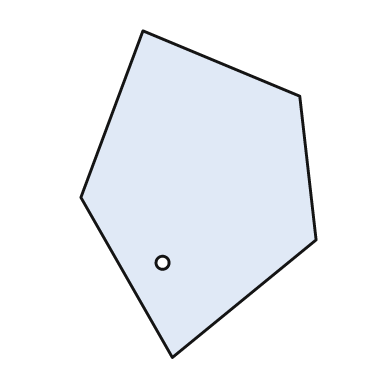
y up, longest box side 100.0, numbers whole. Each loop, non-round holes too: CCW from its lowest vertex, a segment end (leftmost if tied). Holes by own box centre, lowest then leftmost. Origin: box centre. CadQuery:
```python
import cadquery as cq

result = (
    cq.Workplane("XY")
    .moveTo(-8.0, -50.0)
    .lineTo(36.0, -14.0)
    .lineTo(31.0, 30.0)
    .lineTo(-17.0, 50.0)
    .lineTo(-36.0, -1.0)
    .close()
    .moveTo(-11.0, -21.0)
    .circle(2.0)
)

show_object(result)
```